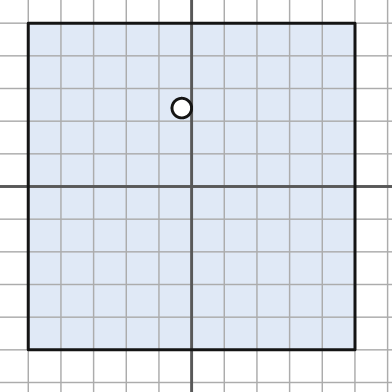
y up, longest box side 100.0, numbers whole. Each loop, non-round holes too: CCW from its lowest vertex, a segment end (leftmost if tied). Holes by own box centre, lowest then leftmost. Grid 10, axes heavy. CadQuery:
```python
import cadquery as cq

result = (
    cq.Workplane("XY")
    .moveTo(-50.0, -50.0)
    .lineTo(50.0, -50.0)
    .lineTo(50.0, 50.0)
    .lineTo(-50.0, 50.0)
    .close()
    .moveTo(-3.0, 24.0)
    .circle(3.0)
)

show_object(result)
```